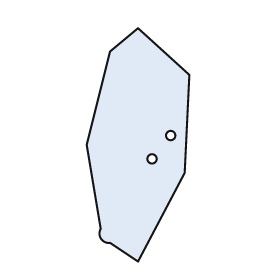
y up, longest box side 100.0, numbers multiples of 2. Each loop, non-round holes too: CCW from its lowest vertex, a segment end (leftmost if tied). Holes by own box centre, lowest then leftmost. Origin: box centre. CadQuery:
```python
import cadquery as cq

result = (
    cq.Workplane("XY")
    .moveTo(0.0, -50.0)
    .lineTo(20.0, -12.0)
    .lineTo(22.0, 30.0)
    .lineTo(0.0, 50.0)
    .lineTo(-12.0, 40.0)
    .lineTo(-22.0, 0.0)
    .lineTo(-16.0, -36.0)
    .threePointArc((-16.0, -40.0), (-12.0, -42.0))
    .close()
    .moveTo(6.0, -6.0)
    .circle(2.0)
    .moveTo(14.0, 4.0)
    .circle(2.0)
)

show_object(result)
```